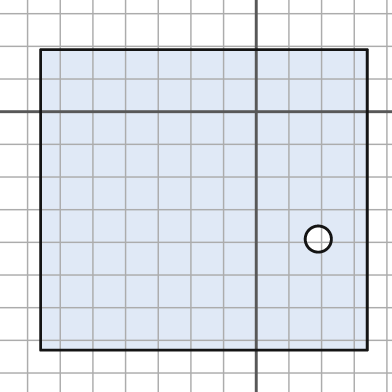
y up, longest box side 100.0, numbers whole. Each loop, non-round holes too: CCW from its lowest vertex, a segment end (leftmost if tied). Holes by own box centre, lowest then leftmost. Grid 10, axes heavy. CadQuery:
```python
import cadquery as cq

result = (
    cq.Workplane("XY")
    .moveTo(-66.0, -73.0)
    .lineTo(34.0, -73.0)
    .lineTo(34.0, 19.0)
    .lineTo(-66.0, 19.0)
    .close()
    .moveTo(19.0, -39.0)
    .circle(4.0)
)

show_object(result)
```